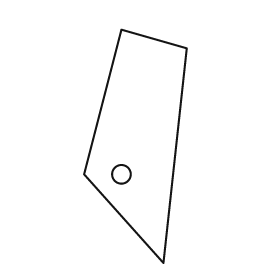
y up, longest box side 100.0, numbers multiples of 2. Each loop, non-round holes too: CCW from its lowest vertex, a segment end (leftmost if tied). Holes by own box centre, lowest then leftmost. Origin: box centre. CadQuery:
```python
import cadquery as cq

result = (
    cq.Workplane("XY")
    .moveTo(12.0, -50.0)
    .lineTo(22.0, 42.0)
    .lineTo(-6.0, 50.0)
    .lineTo(-22.0, -12.0)
    .close()
    .moveTo(-6.0, -12.0)
    .circle(4.0)
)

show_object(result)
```